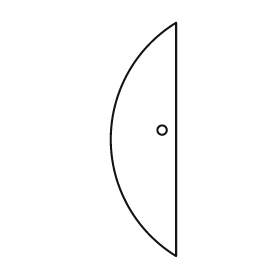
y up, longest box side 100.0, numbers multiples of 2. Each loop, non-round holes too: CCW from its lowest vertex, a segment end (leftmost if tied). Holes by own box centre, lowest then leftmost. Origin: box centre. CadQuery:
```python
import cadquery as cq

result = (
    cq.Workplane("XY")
    .moveTo(14.0, -50.0)
    .lineTo(14.0, 50.0)
    .threePointArc((-14.0, 0.0), (14.0, -50.0))
    .close()
    .moveTo(8.0, 4.0)
    .circle(2.0)
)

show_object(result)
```